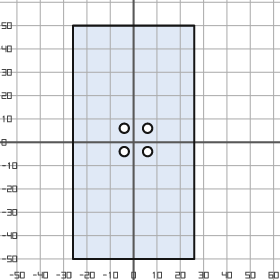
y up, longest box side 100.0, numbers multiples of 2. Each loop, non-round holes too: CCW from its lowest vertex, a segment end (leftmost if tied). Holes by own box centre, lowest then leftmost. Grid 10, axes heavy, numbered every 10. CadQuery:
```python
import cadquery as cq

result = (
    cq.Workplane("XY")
    .moveTo(-26.0, -50.0)
    .lineTo(26.0, -50.0)
    .lineTo(26.0, 50.0)
    .lineTo(-26.0, 50.0)
    .close()
    .moveTo(-4.0, -4.0)
    .circle(2.0)
    .moveTo(6.0, -4.0)
    .circle(2.0)
    .moveTo(-4.0, 6.0)
    .circle(2.0)
    .moveTo(6.0, 6.0)
    .circle(2.0)
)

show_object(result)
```